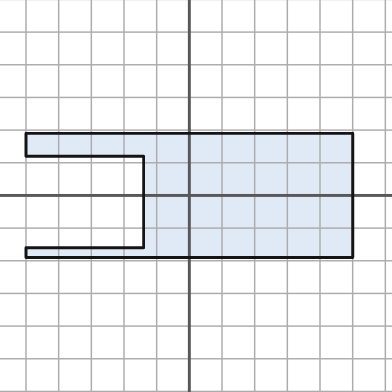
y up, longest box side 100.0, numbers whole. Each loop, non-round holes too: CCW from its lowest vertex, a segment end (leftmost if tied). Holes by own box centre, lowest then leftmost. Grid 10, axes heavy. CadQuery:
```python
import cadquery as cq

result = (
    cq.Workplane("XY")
    .moveTo(-50.0, -19.0)
    .lineTo(50.0, -19.0)
    .lineTo(50.0, 19.0)
    .lineTo(-50.0, 19.0)
    .lineTo(-50.0, 12.0)
    .lineTo(-14.0, 12.0)
    .lineTo(-14.0, -16.0)
    .lineTo(-50.0, -16.0)
    .close()
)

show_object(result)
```